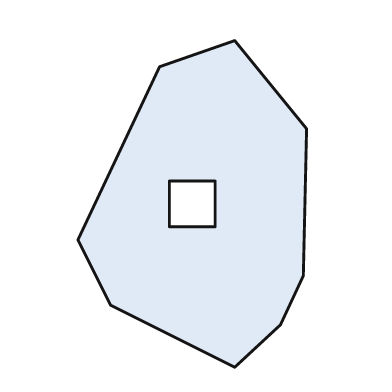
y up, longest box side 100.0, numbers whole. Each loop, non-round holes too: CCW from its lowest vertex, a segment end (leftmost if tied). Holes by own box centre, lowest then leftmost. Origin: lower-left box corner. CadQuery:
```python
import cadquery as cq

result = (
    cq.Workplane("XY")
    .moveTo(48.0, 0.0)
    .lineTo(62.0, 13.0)
    .lineTo(69.0, 28.0)
    .lineTo(70.0, 73.0)
    .lineTo(48.0, 100.0)
    .lineTo(25.0, 92.0)
    .lineTo(0.0, 39.0)
    .lineTo(10.0, 19.0)
    .close()
    .moveTo(28.0, 43.0)
    .lineTo(42.0, 43.0)
    .lineTo(42.0, 57.0)
    .lineTo(28.0, 57.0)
    .close()
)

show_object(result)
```